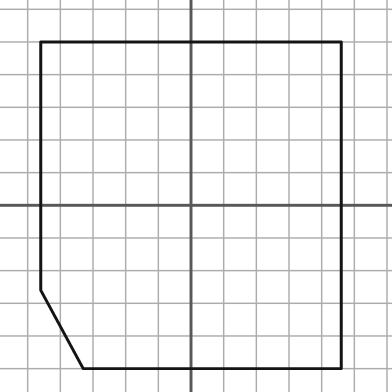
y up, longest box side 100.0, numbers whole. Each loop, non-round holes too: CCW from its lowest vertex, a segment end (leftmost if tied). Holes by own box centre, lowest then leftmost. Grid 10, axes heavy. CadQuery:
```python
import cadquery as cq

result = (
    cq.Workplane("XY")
    .moveTo(-33.0, -50.0)
    .lineTo(46.0, -50.0)
    .lineTo(46.0, 50.0)
    .lineTo(-46.0, 50.0)
    .lineTo(-46.0, -26.0)
    .close()
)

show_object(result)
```